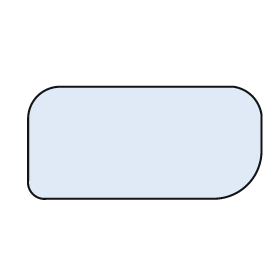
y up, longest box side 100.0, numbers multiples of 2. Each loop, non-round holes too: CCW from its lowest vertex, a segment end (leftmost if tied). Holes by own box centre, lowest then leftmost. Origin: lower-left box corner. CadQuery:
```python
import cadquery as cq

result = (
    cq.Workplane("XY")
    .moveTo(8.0, 0.0)
    .lineTo(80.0, 0.0)
    .threePointArc((94.0, 6.0), (100.0, 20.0))
    .lineTo(100.0, 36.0)
    .threePointArc((96.0, 44.0), (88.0, 48.0))
    .lineTo(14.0, 48.0)
    .threePointArc((4.0, 44.0), (0.0, 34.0))
    .lineTo(0.0, 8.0)
    .threePointArc((2.0, 2.0), (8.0, 0.0))
    .close()
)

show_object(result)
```